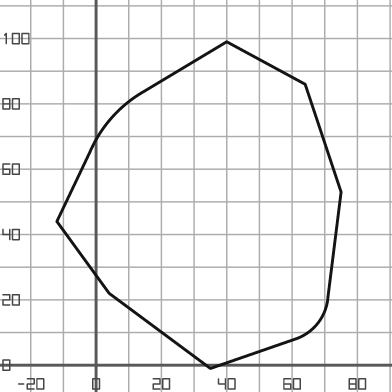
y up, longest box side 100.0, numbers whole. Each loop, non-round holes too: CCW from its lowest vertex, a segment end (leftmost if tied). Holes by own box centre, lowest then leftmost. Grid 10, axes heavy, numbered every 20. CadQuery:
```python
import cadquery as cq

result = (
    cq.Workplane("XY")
    .moveTo(35.0, -1.0)
    .lineTo(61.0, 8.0)
    .threePointArc((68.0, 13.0), (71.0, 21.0))
    .lineTo(75.0, 53.0)
    .lineTo(64.0, 86.0)
    .lineTo(40.0, 99.0)
    .lineTo(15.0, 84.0)
    .threePointArc((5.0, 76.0), (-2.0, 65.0))
    .lineTo(-12.0, 44.0)
    .lineTo(4.0, 22.0)
    .close()
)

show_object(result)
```